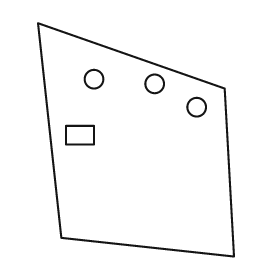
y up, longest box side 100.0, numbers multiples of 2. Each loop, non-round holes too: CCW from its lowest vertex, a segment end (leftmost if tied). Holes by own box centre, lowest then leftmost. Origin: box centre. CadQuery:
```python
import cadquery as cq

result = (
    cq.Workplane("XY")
    .moveTo(42.0, -50.0)
    .lineTo(38.0, 22.0)
    .lineTo(-42.0, 50.0)
    .lineTo(-32.0, -42.0)
    .close()
    .moveTo(-30.0, -2.0)
    .lineTo(-18.0, -2.0)
    .lineTo(-18.0, 6.0)
    .lineTo(-30.0, 6.0)
    .close()
    .moveTo(26.0, 14.0)
    .circle(4.0)
    .moveTo(8.0, 24.0)
    .circle(4.0)
    .moveTo(-18.0, 26.0)
    .circle(4.0)
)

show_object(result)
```